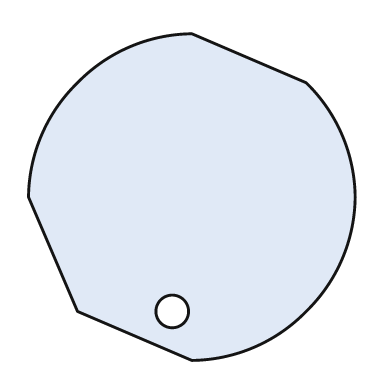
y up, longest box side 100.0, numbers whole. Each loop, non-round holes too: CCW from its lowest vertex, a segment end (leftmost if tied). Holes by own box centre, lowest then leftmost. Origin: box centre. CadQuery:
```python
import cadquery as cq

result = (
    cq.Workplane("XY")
    .moveTo(0.0, -50.0)
    .threePointArc((19.0, -46.0), (35.0, -35.0))
    .threePointArc((46.0, -19.0), (50.0, 0.0))
    .threePointArc((46.0, 19.0), (35.0, 35.0))
    .lineTo(0.0, 50.0)
    .threePointArc((-19.0, 46.0), (-35.0, 35.0))
    .threePointArc((-46.0, 19.0), (-50.0, 0.0))
    .lineTo(-35.0, -35.0)
    .close()
    .moveTo(-6.0, -35.0)
    .circle(5.0)
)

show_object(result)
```